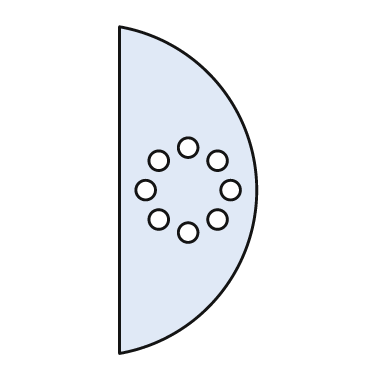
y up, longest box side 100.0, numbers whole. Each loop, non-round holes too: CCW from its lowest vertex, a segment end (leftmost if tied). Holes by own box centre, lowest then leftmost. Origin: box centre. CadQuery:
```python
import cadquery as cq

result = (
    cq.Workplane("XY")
    .moveTo(-21.0, -50.0)
    .threePointArc((21.0, 0.0), (-21.0, 50.0))
    .close()
    .moveTo(0.0, -13.0)
    .circle(3.0)
    .moveTo(-9.0, -9.0)
    .circle(3.0)
    .moveTo(9.0, -9.0)
    .circle(3.0)
    .moveTo(-13.0, 0.0)
    .circle(3.0)
    .moveTo(13.0, 0.0)
    .circle(3.0)
    .moveTo(-9.0, 9.0)
    .circle(3.0)
    .moveTo(9.0, 9.0)
    .circle(3.0)
    .moveTo(0.0, 13.0)
    .circle(3.0)
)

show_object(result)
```